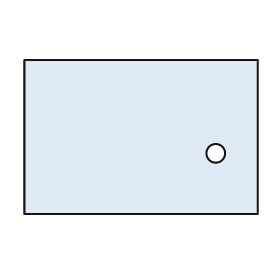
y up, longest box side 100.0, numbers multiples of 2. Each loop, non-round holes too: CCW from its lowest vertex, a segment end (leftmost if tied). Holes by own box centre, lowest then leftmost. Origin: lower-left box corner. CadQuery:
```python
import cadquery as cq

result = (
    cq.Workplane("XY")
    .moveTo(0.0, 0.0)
    .lineTo(100.0, 0.0)
    .lineTo(100.0, 66.0)
    .lineTo(0.0, 66.0)
    .close()
    .moveTo(82.0, 26.0)
    .circle(4.0)
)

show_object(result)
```